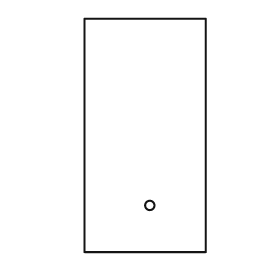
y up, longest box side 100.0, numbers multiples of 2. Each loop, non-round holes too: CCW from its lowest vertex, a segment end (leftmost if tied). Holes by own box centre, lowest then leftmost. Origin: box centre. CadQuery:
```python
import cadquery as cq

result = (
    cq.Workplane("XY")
    .moveTo(-26.0, -50.0)
    .lineTo(26.0, -50.0)
    .lineTo(26.0, 50.0)
    .lineTo(-26.0, 50.0)
    .close()
    .moveTo(2.0, -30.0)
    .circle(2.0)
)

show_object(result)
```